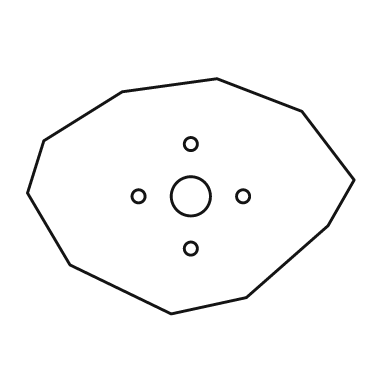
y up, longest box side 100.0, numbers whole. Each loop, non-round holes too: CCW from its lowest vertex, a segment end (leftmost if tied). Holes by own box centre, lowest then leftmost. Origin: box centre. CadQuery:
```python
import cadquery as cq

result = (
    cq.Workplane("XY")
    .moveTo(-6.0, -36.0)
    .lineTo(17.0, -31.0)
    .lineTo(42.0, -9.0)
    .lineTo(50.0, 5.0)
    .lineTo(34.0, 26.0)
    .lineTo(8.0, 36.0)
    .lineTo(-21.0, 32.0)
    .lineTo(-45.0, 17.0)
    .lineTo(-50.0, 1.0)
    .lineTo(-37.0, -21.0)
    .close()
    .moveTo(0.0, -16.0)
    .circle(2.0)
    .moveTo(-16.0, 0.0)
    .circle(2.0)
    .moveTo(0.0, 0.0)
    .circle(6.0)
    .moveTo(16.0, 0.0)
    .circle(2.0)
    .moveTo(0.0, 16.0)
    .circle(2.0)
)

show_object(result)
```